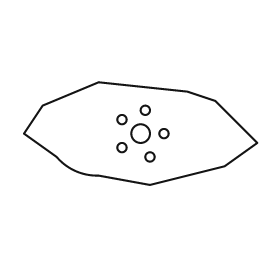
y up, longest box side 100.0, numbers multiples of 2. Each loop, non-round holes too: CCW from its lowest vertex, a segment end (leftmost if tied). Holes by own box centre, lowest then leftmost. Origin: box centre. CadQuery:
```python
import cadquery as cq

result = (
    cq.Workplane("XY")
    .moveTo(4.0, -22.0)
    .lineTo(36.0, -14.0)
    .lineTo(50.0, -4.0)
    .lineTo(32.0, 14.0)
    .lineTo(20.0, 18.0)
    .lineTo(-18.0, 22.0)
    .lineTo(-42.0, 12.0)
    .lineTo(-50.0, 0.0)
    .lineTo(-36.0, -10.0)
    .threePointArc((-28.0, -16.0), (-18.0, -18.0))
    .close()
    .moveTo(4.0, -10.0)
    .circle(2.0)
    .moveTo(-8.0, -6.0)
    .circle(2.0)
    .moveTo(0.0, 0.0)
    .circle(4.0)
    .moveTo(10.0, 0.0)
    .circle(2.0)
    .moveTo(-8.0, 6.0)
    .circle(2.0)
    .moveTo(2.0, 10.0)
    .circle(2.0)
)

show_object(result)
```